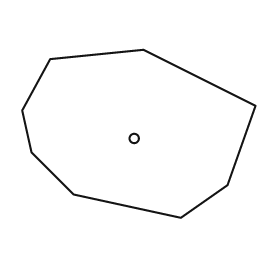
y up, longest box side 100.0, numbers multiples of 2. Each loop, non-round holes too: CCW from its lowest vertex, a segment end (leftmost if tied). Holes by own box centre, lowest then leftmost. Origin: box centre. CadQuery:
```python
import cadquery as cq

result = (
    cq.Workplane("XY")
    .moveTo(18.0, -36.0)
    .lineTo(38.0, -22.0)
    .lineTo(50.0, 12.0)
    .lineTo(2.0, 36.0)
    .lineTo(-38.0, 32.0)
    .lineTo(-50.0, 10.0)
    .lineTo(-46.0, -8.0)
    .lineTo(-28.0, -26.0)
    .close()
    .moveTo(-2.0, -2.0)
    .circle(2.0)
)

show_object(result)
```